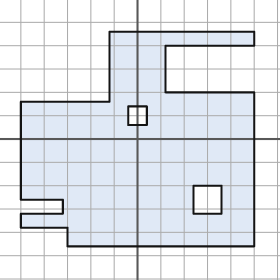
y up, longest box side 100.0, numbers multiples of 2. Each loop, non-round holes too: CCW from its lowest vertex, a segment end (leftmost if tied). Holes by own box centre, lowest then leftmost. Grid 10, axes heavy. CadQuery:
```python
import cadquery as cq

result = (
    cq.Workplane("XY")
    .moveTo(-30.0, -46.0)
    .lineTo(50.0, -46.0)
    .lineTo(50.0, 20.0)
    .lineTo(12.0, 20.0)
    .lineTo(12.0, 40.0)
    .lineTo(50.0, 40.0)
    .lineTo(50.0, 46.0)
    .lineTo(-12.0, 46.0)
    .lineTo(-12.0, 16.0)
    .lineTo(-50.0, 16.0)
    .lineTo(-50.0, -26.0)
    .lineTo(-32.0, -26.0)
    .lineTo(-32.0, -32.0)
    .lineTo(-50.0, -32.0)
    .lineTo(-50.0, -38.0)
    .lineTo(-30.0, -38.0)
    .close()
    .moveTo(24.0, -32.0)
    .lineTo(36.0, -32.0)
    .lineTo(36.0, -20.0)
    .lineTo(24.0, -20.0)
    .close()
    .moveTo(-4.0, 6.0)
    .lineTo(4.0, 6.0)
    .lineTo(4.0, 14.0)
    .lineTo(-4.0, 14.0)
    .close()
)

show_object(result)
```